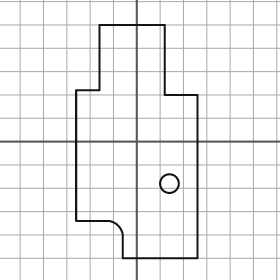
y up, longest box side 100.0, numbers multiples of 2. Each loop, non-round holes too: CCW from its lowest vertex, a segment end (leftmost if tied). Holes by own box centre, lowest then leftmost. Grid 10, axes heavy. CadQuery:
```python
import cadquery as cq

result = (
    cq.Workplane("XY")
    .moveTo(-6.0, -50.0)
    .lineTo(26.0, -50.0)
    .lineTo(26.0, 20.0)
    .lineTo(12.0, 20.0)
    .lineTo(12.0, 50.0)
    .lineTo(-16.0, 50.0)
    .lineTo(-16.0, 22.0)
    .lineTo(-26.0, 22.0)
    .lineTo(-26.0, -34.0)
    .lineTo(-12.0, -34.0)
    .threePointArc((-8.0, -36.0), (-6.0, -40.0))
    .close()
    .moveTo(14.0, -18.0)
    .circle(4.0)
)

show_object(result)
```